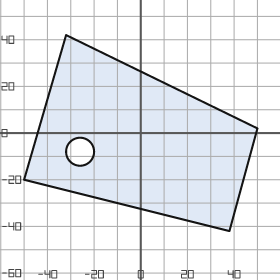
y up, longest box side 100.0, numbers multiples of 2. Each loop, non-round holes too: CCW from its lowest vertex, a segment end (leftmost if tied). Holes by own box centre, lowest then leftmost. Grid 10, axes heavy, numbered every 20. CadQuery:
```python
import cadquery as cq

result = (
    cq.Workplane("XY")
    .moveTo(38.0, -42.0)
    .lineTo(50.0, 2.0)
    .lineTo(-32.0, 42.0)
    .lineTo(-50.0, -20.0)
    .close()
    .moveTo(-26.0, -8.0)
    .circle(6.0)
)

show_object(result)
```